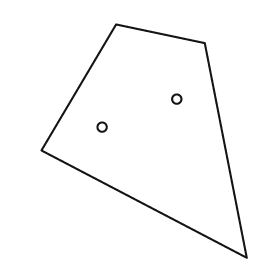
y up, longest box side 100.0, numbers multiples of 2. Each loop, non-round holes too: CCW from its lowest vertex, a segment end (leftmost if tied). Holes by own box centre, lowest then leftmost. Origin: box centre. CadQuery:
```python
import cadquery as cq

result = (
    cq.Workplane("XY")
    .moveTo(44.0, -50.0)
    .lineTo(26.0, 42.0)
    .lineTo(-12.0, 50.0)
    .lineTo(-44.0, -4.0)
    .close()
    .moveTo(-18.0, 6.0)
    .circle(2.0)
    .moveTo(14.0, 18.0)
    .circle(2.0)
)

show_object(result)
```